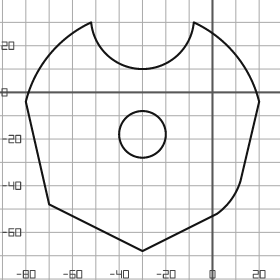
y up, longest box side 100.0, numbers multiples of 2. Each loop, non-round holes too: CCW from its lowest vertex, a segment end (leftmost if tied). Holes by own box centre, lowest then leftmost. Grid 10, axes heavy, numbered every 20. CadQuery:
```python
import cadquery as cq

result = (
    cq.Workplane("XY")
    .moveTo(-30.0, -68.0)
    .lineTo(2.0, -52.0)
    .threePointArc((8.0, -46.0), (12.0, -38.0))
    .lineTo(20.0, -4.0)
    .threePointArc((10.0, 16.0), (-8.0, 30.0))
    .threePointArc((-30.0, 10.0), (-52.0, 30.0))
    .threePointArc((-70.0, 16.0), (-80.0, -4.0))
    .lineTo(-70.0, -48.0)
    .close()
    .moveTo(-30.0, -18.0)
    .circle(10.0)
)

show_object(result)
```